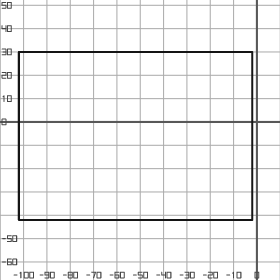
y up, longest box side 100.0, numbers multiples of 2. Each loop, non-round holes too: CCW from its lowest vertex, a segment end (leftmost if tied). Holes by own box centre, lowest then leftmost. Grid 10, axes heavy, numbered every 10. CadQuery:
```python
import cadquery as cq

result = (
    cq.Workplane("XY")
    .moveTo(-102.0, -42.0)
    .lineTo(-2.0, -42.0)
    .lineTo(-2.0, 30.0)
    .lineTo(-102.0, 30.0)
    .close()
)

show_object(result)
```